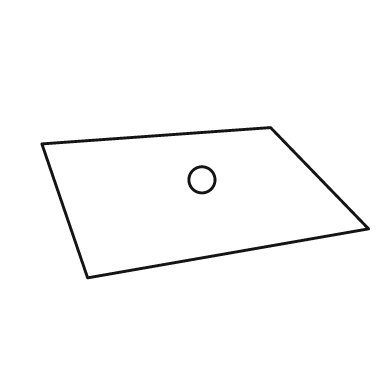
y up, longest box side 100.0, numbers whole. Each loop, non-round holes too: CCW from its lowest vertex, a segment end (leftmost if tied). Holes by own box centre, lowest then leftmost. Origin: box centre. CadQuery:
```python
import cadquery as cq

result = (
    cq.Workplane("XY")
    .moveTo(-36.0, -23.0)
    .lineTo(50.0, -8.0)
    .lineTo(20.0, 23.0)
    .lineTo(-50.0, 18.0)
    .close()
    .moveTo(-1.0, 7.0)
    .circle(4.0)
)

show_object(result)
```